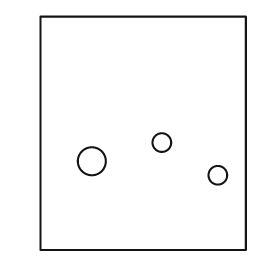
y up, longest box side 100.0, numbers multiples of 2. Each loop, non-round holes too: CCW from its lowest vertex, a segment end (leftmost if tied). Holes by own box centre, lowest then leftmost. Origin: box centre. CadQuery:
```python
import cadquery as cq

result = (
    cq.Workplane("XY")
    .moveTo(-44.0, -50.0)
    .lineTo(44.0, -50.0)
    .lineTo(44.0, 50.0)
    .lineTo(-44.0, 50.0)
    .close()
    .moveTo(32.0, -18.0)
    .circle(4.0)
    .moveTo(-22.0, -12.0)
    .circle(6.0)
    .moveTo(8.0, -4.0)
    .circle(4.0)
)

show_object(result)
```